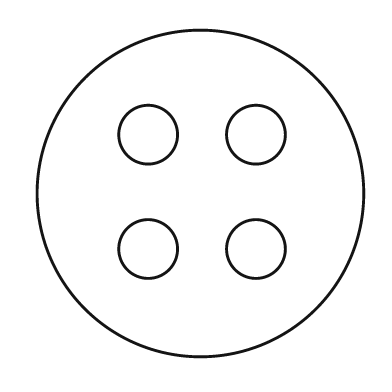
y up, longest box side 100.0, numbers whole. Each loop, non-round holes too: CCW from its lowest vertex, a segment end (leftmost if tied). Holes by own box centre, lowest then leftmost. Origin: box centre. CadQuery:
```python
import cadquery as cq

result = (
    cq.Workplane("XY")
    .moveTo(0.0, 0.0)
    .circle(50.0)
    .moveTo(-16.0, -17.0)
    .circle(9.0)
    .moveTo(17.0, -17.0)
    .circle(9.0)
    .moveTo(-16.0, 18.0)
    .circle(9.0)
    .moveTo(17.0, 18.0)
    .circle(9.0)
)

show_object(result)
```